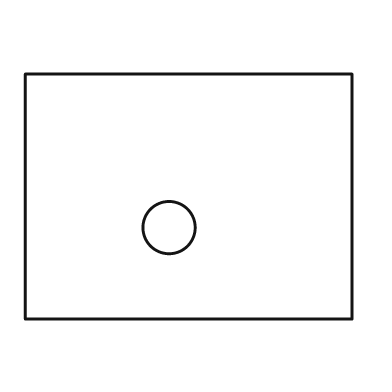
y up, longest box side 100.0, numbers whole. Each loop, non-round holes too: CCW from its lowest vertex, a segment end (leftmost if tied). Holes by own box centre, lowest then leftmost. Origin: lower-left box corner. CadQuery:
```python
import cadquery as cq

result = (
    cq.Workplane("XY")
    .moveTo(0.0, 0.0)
    .lineTo(100.0, 0.0)
    .lineTo(100.0, 75.0)
    .lineTo(0.0, 75.0)
    .close()
    .moveTo(44.0, 28.0)
    .circle(8.0)
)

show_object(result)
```